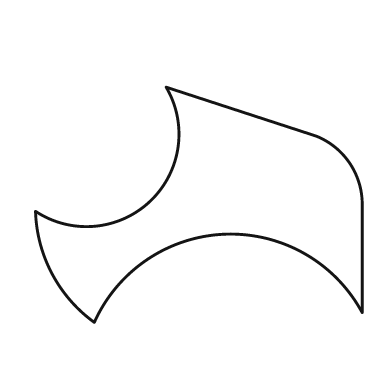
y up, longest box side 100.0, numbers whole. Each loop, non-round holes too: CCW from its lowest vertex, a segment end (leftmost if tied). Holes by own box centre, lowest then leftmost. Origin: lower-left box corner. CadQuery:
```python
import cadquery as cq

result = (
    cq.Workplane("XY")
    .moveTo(18.0, 0.0)
    .threePointArc((58.0, 27.0), (100.0, 3.0))
    .lineTo(100.0, 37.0)
    .threePointArc((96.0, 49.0), (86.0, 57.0))
    .lineTo(40.0, 72.0)
    .threePointArc((35.0, 37.0), (0.0, 34.0))
    .threePointArc((5.0, 15.0), (18.0, 0.0))
    .close()
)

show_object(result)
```